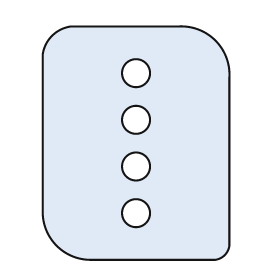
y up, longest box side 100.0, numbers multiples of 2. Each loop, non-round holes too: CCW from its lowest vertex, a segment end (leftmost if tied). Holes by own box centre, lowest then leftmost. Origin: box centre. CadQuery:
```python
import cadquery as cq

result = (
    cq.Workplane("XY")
    .moveTo(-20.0, -50.0)
    .lineTo(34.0, -50.0)
    .threePointArc((38.0, -48.0), (40.0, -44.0))
    .lineTo(40.0, 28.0)
    .threePointArc((34.0, 44.0), (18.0, 50.0))
    .lineTo(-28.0, 50.0)
    .threePointArc((-36.0, 46.0), (-40.0, 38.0))
    .lineTo(-40.0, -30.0)
    .threePointArc((-34.0, -44.0), (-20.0, -50.0))
    .close()
    .moveTo(0.0, -30.0)
    .circle(6.0)
    .moveTo(0.0, -10.0)
    .circle(6.0)
    .moveTo(0.0, 10.0)
    .circle(6.0)
    .moveTo(0.0, 30.0)
    .circle(6.0)
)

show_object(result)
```